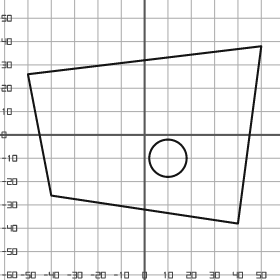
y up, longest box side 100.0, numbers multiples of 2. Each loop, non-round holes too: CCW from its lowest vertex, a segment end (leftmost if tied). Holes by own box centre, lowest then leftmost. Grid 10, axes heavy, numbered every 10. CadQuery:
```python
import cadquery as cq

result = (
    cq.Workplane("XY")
    .moveTo(40.0, -38.0)
    .lineTo(50.0, 38.0)
    .lineTo(-50.0, 26.0)
    .lineTo(-40.0, -26.0)
    .close()
    .moveTo(10.0, -10.0)
    .circle(8.0)
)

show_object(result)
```